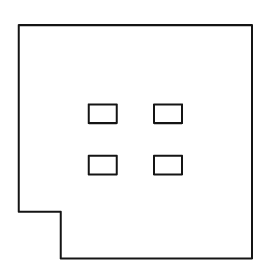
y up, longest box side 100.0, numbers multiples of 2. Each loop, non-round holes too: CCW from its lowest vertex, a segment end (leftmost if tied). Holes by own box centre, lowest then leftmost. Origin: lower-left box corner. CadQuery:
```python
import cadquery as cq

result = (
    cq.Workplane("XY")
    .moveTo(18.0, 0.0)
    .lineTo(100.0, 0.0)
    .lineTo(100.0, 100.0)
    .lineTo(0.0, 100.0)
    .lineTo(0.0, 20.0)
    .lineTo(18.0, 20.0)
    .close()
    .moveTo(30.0, 36.0)
    .lineTo(42.0, 36.0)
    .lineTo(42.0, 44.0)
    .lineTo(30.0, 44.0)
    .close()
    .moveTo(58.0, 36.0)
    .lineTo(70.0, 36.0)
    .lineTo(70.0, 44.0)
    .lineTo(58.0, 44.0)
    .close()
    .moveTo(30.0, 58.0)
    .lineTo(42.0, 58.0)
    .lineTo(42.0, 66.0)
    .lineTo(30.0, 66.0)
    .close()
    .moveTo(58.0, 58.0)
    .lineTo(70.0, 58.0)
    .lineTo(70.0, 66.0)
    .lineTo(58.0, 66.0)
    .close()
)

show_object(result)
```